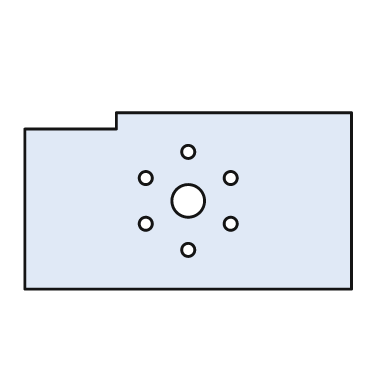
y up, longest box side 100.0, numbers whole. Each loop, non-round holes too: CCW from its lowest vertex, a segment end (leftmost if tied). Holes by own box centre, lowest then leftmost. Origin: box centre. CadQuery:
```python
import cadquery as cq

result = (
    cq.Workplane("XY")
    .moveTo(-50.0, -27.0)
    .lineTo(50.0, -27.0)
    .lineTo(50.0, 27.0)
    .lineTo(-22.0, 27.0)
    .lineTo(-22.0, 22.0)
    .lineTo(-50.0, 22.0)
    .close()
    .moveTo(0.0, -15.0)
    .circle(2.0)
    .moveTo(-13.0, -7.0)
    .circle(2.0)
    .moveTo(13.0, -7.0)
    .circle(2.0)
    .moveTo(0.0, 0.0)
    .circle(5.0)
    .moveTo(-13.0, 7.0)
    .circle(2.0)
    .moveTo(13.0, 7.0)
    .circle(2.0)
    .moveTo(0.0, 15.0)
    .circle(2.0)
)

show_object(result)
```